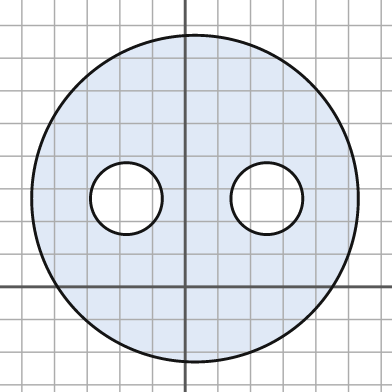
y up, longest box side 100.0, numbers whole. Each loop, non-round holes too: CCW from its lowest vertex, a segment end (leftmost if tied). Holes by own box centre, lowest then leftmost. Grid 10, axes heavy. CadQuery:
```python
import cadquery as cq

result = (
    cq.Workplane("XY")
    .moveTo(3.0, 27.0)
    .circle(50.0)
    .moveTo(-18.0, 27.0)
    .circle(11.0)
    .moveTo(25.0, 27.0)
    .circle(11.0)
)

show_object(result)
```